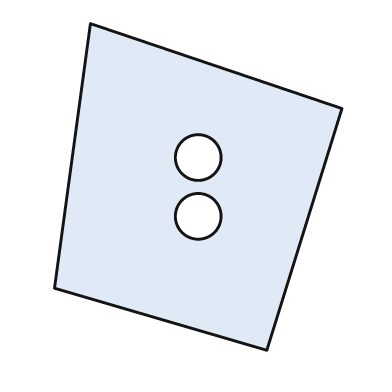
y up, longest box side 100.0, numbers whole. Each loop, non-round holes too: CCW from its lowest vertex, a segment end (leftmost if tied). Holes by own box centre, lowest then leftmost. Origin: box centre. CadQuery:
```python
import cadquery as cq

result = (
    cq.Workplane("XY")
    .moveTo(21.0, -50.0)
    .lineTo(44.0, 24.0)
    .lineTo(-33.0, 50.0)
    .lineTo(-44.0, -31.0)
    .close()
    .moveTo(0.0, -9.0)
    .circle(7.0)
    .moveTo(0.0, 9.0)
    .circle(7.0)
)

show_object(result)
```